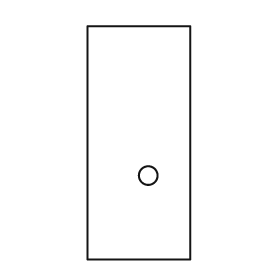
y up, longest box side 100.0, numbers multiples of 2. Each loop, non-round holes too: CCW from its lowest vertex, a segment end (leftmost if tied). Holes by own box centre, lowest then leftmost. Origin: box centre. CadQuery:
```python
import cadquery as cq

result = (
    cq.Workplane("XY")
    .moveTo(-22.0, -50.0)
    .lineTo(22.0, -50.0)
    .lineTo(22.0, 50.0)
    .lineTo(-22.0, 50.0)
    .close()
    .moveTo(4.0, -14.0)
    .circle(4.0)
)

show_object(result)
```